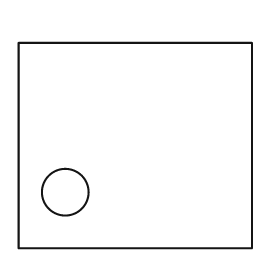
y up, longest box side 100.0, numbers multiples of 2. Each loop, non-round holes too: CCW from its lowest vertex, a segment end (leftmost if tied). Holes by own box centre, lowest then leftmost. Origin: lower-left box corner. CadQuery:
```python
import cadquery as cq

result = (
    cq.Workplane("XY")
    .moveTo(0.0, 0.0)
    .lineTo(100.0, 0.0)
    .lineTo(100.0, 88.0)
    .lineTo(0.0, 88.0)
    .close()
    .moveTo(20.0, 24.0)
    .circle(10.0)
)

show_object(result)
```